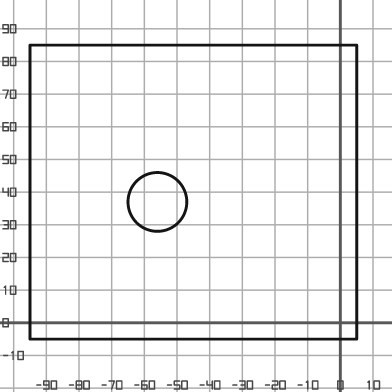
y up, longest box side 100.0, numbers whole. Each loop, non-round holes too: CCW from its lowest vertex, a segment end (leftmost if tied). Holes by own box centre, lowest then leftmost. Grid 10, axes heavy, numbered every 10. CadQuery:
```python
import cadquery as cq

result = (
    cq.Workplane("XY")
    .moveTo(-95.0, -5.0)
    .lineTo(5.0, -5.0)
    .lineTo(5.0, 85.0)
    .lineTo(-95.0, 85.0)
    .close()
    .moveTo(-56.0, 37.0)
    .circle(9.0)
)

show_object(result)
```